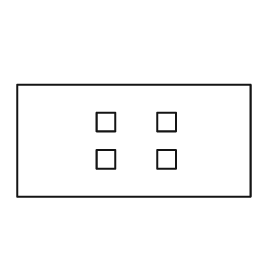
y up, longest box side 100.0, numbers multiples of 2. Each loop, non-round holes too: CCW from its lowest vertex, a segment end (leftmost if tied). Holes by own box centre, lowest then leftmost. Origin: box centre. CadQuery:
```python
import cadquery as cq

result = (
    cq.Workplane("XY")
    .moveTo(-50.0, -24.0)
    .lineTo(50.0, -24.0)
    .lineTo(50.0, 24.0)
    .lineTo(-50.0, 24.0)
    .close()
    .moveTo(-16.0, -12.0)
    .lineTo(-8.0, -12.0)
    .lineTo(-8.0, -4.0)
    .lineTo(-16.0, -4.0)
    .close()
    .moveTo(10.0, -12.0)
    .lineTo(18.0, -12.0)
    .lineTo(18.0, -4.0)
    .lineTo(10.0, -4.0)
    .close()
    .moveTo(-16.0, 4.0)
    .lineTo(-8.0, 4.0)
    .lineTo(-8.0, 12.0)
    .lineTo(-16.0, 12.0)
    .close()
    .moveTo(10.0, 4.0)
    .lineTo(18.0, 4.0)
    .lineTo(18.0, 12.0)
    .lineTo(10.0, 12.0)
    .close()
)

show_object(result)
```